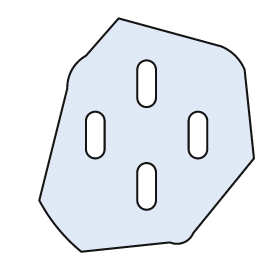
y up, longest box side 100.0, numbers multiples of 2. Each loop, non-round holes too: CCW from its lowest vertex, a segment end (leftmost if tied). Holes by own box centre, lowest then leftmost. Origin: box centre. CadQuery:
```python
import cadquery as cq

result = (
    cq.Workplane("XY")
    .moveTo(-28.0, -50.0)
    .lineTo(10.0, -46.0)
    .threePointArc((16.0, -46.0), (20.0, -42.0))
    .lineTo(46.0, -10.0)
    .lineTo(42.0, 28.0)
    .threePointArc((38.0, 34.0), (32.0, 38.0))
    .lineTo(-12.0, 50.0)
    .lineTo(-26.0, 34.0)
    .threePointArc((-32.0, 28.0), (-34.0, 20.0))
    .lineTo(-46.0, -28.0)
    .threePointArc((-38.0, -40.0), (-28.0, -50.0))
    .close()
    .moveTo(-4.0, -28.0)
    .threePointArc((0.0, -32.0), (4.0, -28.0))
    .lineTo(4.0, -16.0)
    .threePointArc((0.0, -12.0), (-4.0, -16.0))
    .close()
    .moveTo(-26.0, -6.0)
    .threePointArc((-22.0, -10.0), (-18.0, -6.0))
    .lineTo(-18.0, 6.0)
    .threePointArc((-22.0, 10.0), (-26.0, 6.0))
    .close()
    .moveTo(18.0, -6.0)
    .threePointArc((22.0, -10.0), (26.0, -6.0))
    .lineTo(26.0, 6.0)
    .threePointArc((22.0, 10.0), (18.0, 6.0))
    .close()
    .moveTo(-4.0, 16.0)
    .threePointArc((0.0, 12.0), (4.0, 16.0))
    .lineTo(4.0, 28.0)
    .threePointArc((0.0, 32.0), (-4.0, 28.0))
    .close()
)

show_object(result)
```